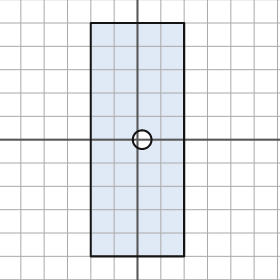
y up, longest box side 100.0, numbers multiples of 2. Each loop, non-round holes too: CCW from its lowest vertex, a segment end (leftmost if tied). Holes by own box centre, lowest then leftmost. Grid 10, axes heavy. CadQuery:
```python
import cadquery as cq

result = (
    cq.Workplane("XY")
    .moveTo(-20.0, -50.0)
    .lineTo(20.0, -50.0)
    .lineTo(20.0, 50.0)
    .lineTo(-20.0, 50.0)
    .close()
    .moveTo(2.0, 0.0)
    .circle(4.0)
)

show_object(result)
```